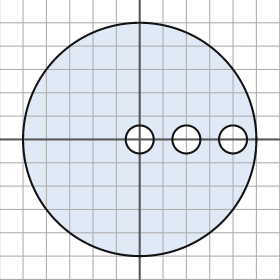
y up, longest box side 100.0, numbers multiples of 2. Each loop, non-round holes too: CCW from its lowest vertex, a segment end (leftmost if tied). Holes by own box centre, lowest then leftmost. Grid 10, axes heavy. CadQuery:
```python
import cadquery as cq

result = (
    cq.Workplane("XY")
    .moveTo(0.0, 0.0)
    .circle(50.0)
    .moveTo(0.0, 0.0)
    .circle(6.0)
    .moveTo(20.0, 0.0)
    .circle(6.0)
    .moveTo(40.0, 0.0)
    .circle(6.0)
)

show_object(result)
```